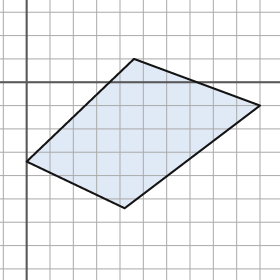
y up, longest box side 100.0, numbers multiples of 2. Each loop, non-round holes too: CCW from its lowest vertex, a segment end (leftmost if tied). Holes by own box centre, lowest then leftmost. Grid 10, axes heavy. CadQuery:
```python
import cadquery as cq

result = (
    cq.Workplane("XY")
    .moveTo(42.0, -54.0)
    .lineTo(100.0, -10.0)
    .lineTo(46.0, 10.0)
    .lineTo(0.0, -34.0)
    .close()
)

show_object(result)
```